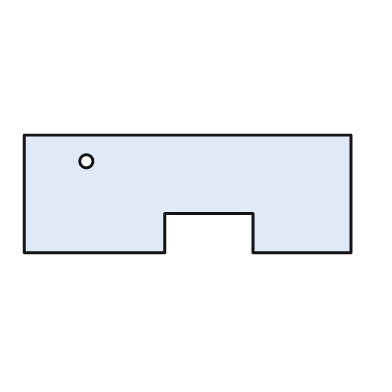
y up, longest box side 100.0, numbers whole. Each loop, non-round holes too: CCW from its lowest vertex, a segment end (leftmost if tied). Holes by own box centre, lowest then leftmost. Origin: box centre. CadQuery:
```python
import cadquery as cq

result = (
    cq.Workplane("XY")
    .moveTo(-50.0, -18.0)
    .lineTo(-7.0, -18.0)
    .lineTo(-7.0, -6.0)
    .lineTo(20.0, -6.0)
    .lineTo(20.0, -18.0)
    .lineTo(50.0, -18.0)
    .lineTo(50.0, 18.0)
    .lineTo(-50.0, 18.0)
    .close()
    .moveTo(-31.0, 10.0)
    .circle(2.0)
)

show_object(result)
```